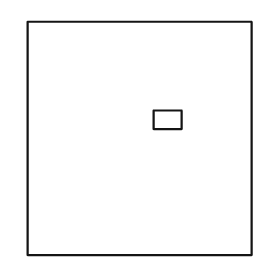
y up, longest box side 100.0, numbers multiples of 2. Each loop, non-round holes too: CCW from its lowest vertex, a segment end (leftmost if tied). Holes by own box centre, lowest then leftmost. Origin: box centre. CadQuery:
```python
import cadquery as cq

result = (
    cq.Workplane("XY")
    .moveTo(-48.0, -50.0)
    .lineTo(48.0, -50.0)
    .lineTo(48.0, 50.0)
    .lineTo(-48.0, 50.0)
    .close()
    .moveTo(6.0, 4.0)
    .lineTo(18.0, 4.0)
    .lineTo(18.0, 12.0)
    .lineTo(6.0, 12.0)
    .close()
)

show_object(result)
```